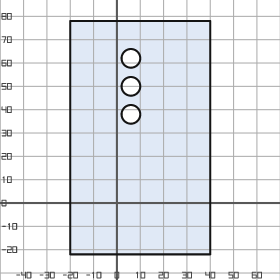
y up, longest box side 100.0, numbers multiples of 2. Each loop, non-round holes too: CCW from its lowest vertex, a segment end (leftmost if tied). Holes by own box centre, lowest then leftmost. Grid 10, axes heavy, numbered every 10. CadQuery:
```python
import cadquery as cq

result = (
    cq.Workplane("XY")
    .moveTo(-20.0, -22.0)
    .lineTo(40.0, -22.0)
    .lineTo(40.0, 78.0)
    .lineTo(-20.0, 78.0)
    .close()
    .moveTo(6.0, 38.0)
    .circle(4.0)
    .moveTo(6.0, 50.0)
    .circle(4.0)
    .moveTo(6.0, 62.0)
    .circle(4.0)
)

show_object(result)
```